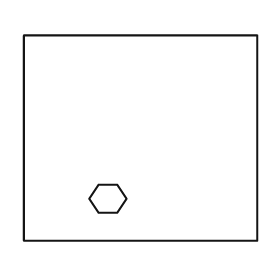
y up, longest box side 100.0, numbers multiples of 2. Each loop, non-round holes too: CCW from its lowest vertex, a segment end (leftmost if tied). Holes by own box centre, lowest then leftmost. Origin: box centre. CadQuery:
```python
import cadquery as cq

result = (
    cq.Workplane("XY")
    .moveTo(-50.0, -44.0)
    .lineTo(50.0, -44.0)
    .lineTo(50.0, 44.0)
    .lineTo(-50.0, 44.0)
    .close()
    .moveTo(-18.0, -32.0)
    .lineTo(-10.0, -32.0)
    .lineTo(-6.0, -26.0)
    .lineTo(-10.0, -20.0)
    .lineTo(-18.0, -20.0)
    .lineTo(-22.0, -26.0)
    .close()
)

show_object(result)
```